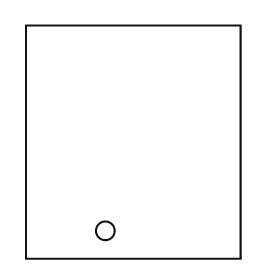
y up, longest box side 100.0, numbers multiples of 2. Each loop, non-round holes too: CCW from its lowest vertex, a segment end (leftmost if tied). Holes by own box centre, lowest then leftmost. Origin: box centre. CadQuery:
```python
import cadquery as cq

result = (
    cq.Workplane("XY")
    .moveTo(-46.0, -50.0)
    .lineTo(46.0, -50.0)
    .lineTo(46.0, 50.0)
    .lineTo(-46.0, 50.0)
    .close()
    .moveTo(-12.0, -38.0)
    .circle(4.0)
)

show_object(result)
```